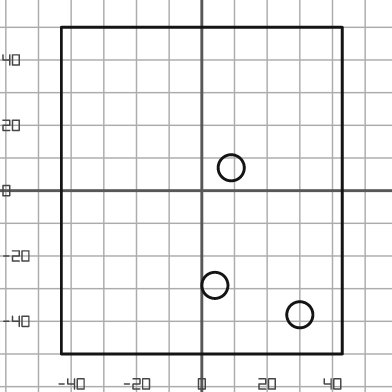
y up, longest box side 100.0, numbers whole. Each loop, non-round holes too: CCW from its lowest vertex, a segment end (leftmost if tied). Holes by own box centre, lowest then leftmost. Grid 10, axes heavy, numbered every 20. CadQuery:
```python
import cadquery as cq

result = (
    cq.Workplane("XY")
    .moveTo(-43.0, -50.0)
    .lineTo(43.0, -50.0)
    .lineTo(43.0, 50.0)
    .lineTo(-43.0, 50.0)
    .close()
    .moveTo(30.0, -38.0)
    .circle(4.0)
    .moveTo(4.0, -29.0)
    .circle(4.0)
    .moveTo(9.0, 7.0)
    .circle(4.0)
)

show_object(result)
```